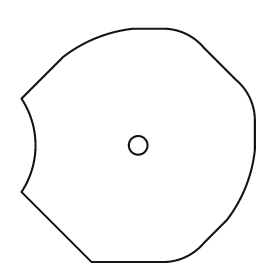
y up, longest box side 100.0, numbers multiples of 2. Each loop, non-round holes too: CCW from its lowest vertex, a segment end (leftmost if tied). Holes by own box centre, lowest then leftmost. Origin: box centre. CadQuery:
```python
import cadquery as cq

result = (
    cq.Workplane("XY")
    .moveTo(-20.0, -50.0)
    .lineTo(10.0, -50.0)
    .threePointArc((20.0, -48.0), (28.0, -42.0))
    .lineTo(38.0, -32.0)
    .threePointArc((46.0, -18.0), (50.0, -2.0))
    .lineTo(50.0, 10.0)
    .threePointArc((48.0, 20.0), (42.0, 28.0))
    .lineTo(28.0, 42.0)
    .threePointArc((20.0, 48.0), (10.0, 50.0))
    .lineTo(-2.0, 50.0)
    .threePointArc((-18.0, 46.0), (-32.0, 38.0))
    .lineTo(-50.0, 20.0)
    .threePointArc((-44.0, 0.0), (-50.0, -20.0))
    .close()
    .moveTo(0.0, 0.0)
    .circle(4.0)
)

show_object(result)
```